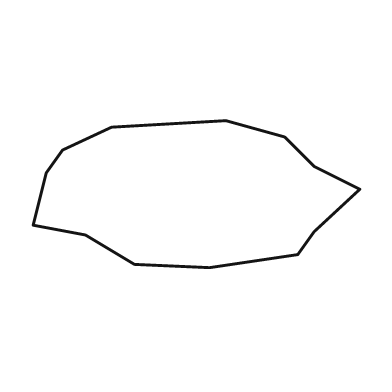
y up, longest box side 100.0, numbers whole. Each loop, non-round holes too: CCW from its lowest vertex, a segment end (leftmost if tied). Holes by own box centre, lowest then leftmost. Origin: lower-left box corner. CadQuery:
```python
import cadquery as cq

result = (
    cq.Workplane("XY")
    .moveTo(54.0, 0.0)
    .lineTo(81.0, 4.0)
    .lineTo(86.0, 11.0)
    .lineTo(100.0, 24.0)
    .lineTo(86.0, 31.0)
    .lineTo(77.0, 40.0)
    .lineTo(59.0, 45.0)
    .lineTo(24.0, 43.0)
    .lineTo(9.0, 36.0)
    .lineTo(4.0, 29.0)
    .lineTo(0.0, 13.0)
    .lineTo(16.0, 10.0)
    .lineTo(31.0, 1.0)
    .close()
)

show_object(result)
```